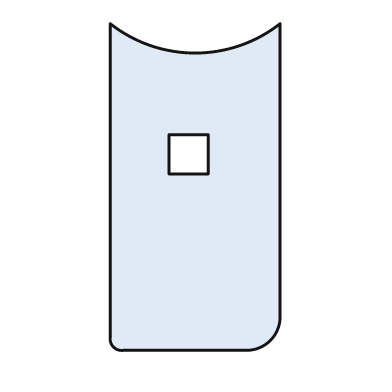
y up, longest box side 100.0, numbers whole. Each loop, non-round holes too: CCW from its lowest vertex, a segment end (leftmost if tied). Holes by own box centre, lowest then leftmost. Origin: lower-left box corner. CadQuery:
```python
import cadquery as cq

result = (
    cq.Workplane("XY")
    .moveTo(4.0, 0.0)
    .lineTo(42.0, 0.0)
    .threePointArc((49.0, 3.0), (52.0, 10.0))
    .lineTo(52.0, 100.0)
    .threePointArc((26.0, 91.0), (0.0, 100.0))
    .lineTo(0.0, 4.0)
    .threePointArc((1.0, 1.0), (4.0, 0.0))
    .close()
    .moveTo(18.0, 54.0)
    .lineTo(30.0, 54.0)
    .lineTo(30.0, 66.0)
    .lineTo(18.0, 66.0)
    .close()
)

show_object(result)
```